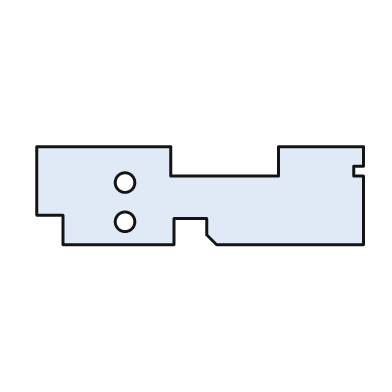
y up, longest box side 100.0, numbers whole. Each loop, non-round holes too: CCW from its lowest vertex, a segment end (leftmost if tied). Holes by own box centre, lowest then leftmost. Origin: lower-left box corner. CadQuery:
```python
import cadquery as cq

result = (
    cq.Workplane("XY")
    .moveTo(8.0, 0.0)
    .lineTo(42.0, 0.0)
    .lineTo(42.0, 8.0)
    .lineTo(52.0, 8.0)
    .lineTo(52.0, 3.0)
    .lineTo(55.0, 0.0)
    .lineTo(100.0, 0.0)
    .lineTo(100.0, 21.0)
    .lineTo(97.0, 21.0)
    .lineTo(97.0, 24.0)
    .lineTo(100.0, 24.0)
    .lineTo(100.0, 30.0)
    .lineTo(74.0, 30.0)
    .lineTo(74.0, 21.0)
    .lineTo(41.0, 21.0)
    .lineTo(41.0, 30.0)
    .lineTo(0.0, 30.0)
    .lineTo(0.0, 9.0)
    .lineTo(8.0, 9.0)
    .close()
    .moveTo(27.0, 7.0)
    .circle(3.0)
    .moveTo(27.0, 19.0)
    .circle(3.0)
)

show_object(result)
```